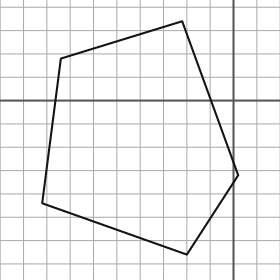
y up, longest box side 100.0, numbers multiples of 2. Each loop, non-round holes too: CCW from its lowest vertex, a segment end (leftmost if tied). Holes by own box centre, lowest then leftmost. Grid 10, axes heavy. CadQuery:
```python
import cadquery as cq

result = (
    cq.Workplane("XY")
    .moveTo(-20.0, -66.0)
    .lineTo(2.0, -32.0)
    .lineTo(-22.0, 34.0)
    .lineTo(-74.0, 18.0)
    .lineTo(-82.0, -44.0)
    .close()
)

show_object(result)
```